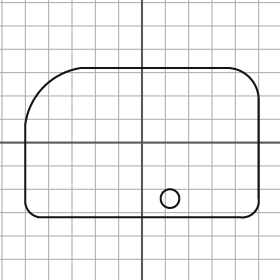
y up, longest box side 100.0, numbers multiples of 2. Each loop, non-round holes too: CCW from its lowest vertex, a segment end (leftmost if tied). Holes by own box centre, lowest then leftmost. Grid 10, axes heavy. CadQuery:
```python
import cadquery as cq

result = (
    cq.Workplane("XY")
    .moveTo(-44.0, -32.0)
    .lineTo(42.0, -32.0)
    .threePointArc((48.0, -30.0), (50.0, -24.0))
    .lineTo(50.0, 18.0)
    .threePointArc((46.0, 28.0), (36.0, 32.0))
    .lineTo(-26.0, 32.0)
    .threePointArc((-42.0, 24.0), (-50.0, 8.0))
    .lineTo(-50.0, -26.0)
    .threePointArc((-48.0, -30.0), (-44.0, -32.0))
    .close()
    .moveTo(12.0, -24.0)
    .circle(4.0)
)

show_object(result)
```